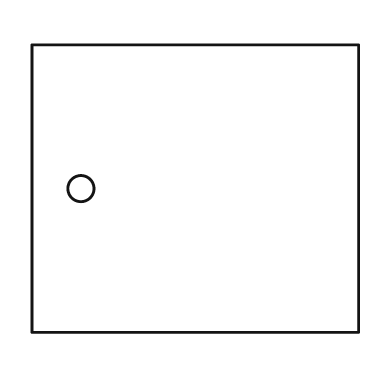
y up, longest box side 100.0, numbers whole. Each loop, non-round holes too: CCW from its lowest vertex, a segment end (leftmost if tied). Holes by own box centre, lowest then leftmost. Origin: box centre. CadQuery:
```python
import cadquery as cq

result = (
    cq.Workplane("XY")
    .moveTo(-50.0, -44.0)
    .lineTo(50.0, -44.0)
    .lineTo(50.0, 44.0)
    .lineTo(-50.0, 44.0)
    .close()
    .moveTo(-35.0, 0.0)
    .circle(4.0)
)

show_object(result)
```